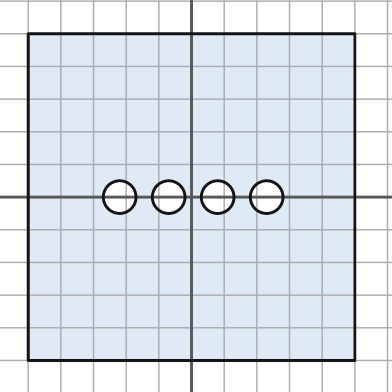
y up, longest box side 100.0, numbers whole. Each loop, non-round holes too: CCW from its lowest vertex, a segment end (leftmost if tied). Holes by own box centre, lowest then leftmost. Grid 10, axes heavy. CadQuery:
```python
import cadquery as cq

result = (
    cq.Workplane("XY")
    .moveTo(-50.0, -50.0)
    .lineTo(50.0, -50.0)
    .lineTo(50.0, 50.0)
    .lineTo(-50.0, 50.0)
    .close()
    .moveTo(-22.0, 0.0)
    .circle(5.0)
    .moveTo(-7.0, 0.0)
    .circle(5.0)
    .moveTo(8.0, 0.0)
    .circle(5.0)
    .moveTo(23.0, 0.0)
    .circle(5.0)
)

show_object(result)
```